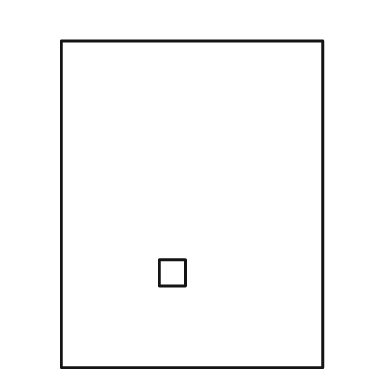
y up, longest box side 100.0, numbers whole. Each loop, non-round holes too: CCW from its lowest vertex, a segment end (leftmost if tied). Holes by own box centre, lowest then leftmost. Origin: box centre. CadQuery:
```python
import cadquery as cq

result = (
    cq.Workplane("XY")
    .moveTo(-40.0, -50.0)
    .lineTo(40.0, -50.0)
    .lineTo(40.0, 50.0)
    .lineTo(-40.0, 50.0)
    .close()
    .moveTo(-10.0, -25.0)
    .lineTo(-2.0, -25.0)
    .lineTo(-2.0, -17.0)
    .lineTo(-10.0, -17.0)
    .close()
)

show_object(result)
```